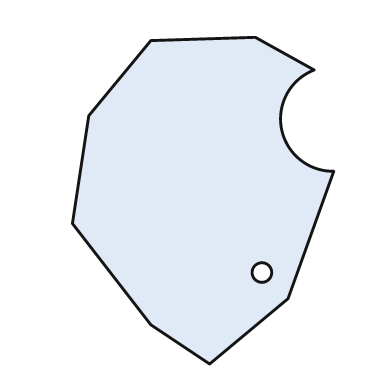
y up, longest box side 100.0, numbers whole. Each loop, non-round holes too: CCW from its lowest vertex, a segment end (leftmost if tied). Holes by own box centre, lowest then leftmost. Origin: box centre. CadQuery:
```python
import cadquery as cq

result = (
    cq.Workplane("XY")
    .moveTo(2.0, -50.0)
    .lineTo(26.0, -30.0)
    .lineTo(40.0, 9.0)
    .threePointArc((24.0, 22.0), (34.0, 40.0))
    .lineTo(16.0, 50.0)
    .lineTo(-16.0, 49.0)
    .lineTo(-35.0, 26.0)
    .lineTo(-40.0, -7.0)
    .lineTo(-16.0, -38.0)
    .close()
    .moveTo(18.0, -22.0)
    .circle(3.0)
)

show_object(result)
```